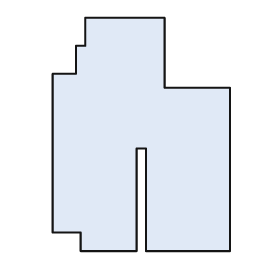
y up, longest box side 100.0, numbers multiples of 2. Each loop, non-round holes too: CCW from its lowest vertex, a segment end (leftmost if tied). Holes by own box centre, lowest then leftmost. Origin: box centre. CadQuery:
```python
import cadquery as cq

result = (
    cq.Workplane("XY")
    .moveTo(-26.0, -50.0)
    .lineTo(-2.0, -50.0)
    .lineTo(-2.0, -6.0)
    .lineTo(2.0, -6.0)
    .lineTo(2.0, -50.0)
    .lineTo(38.0, -50.0)
    .lineTo(38.0, 20.0)
    .lineTo(10.0, 20.0)
    .lineTo(10.0, 50.0)
    .lineTo(-24.0, 50.0)
    .lineTo(-24.0, 38.0)
    .lineTo(-28.0, 38.0)
    .lineTo(-28.0, 26.0)
    .lineTo(-38.0, 26.0)
    .lineTo(-38.0, -42.0)
    .lineTo(-26.0, -42.0)
    .close()
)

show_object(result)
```